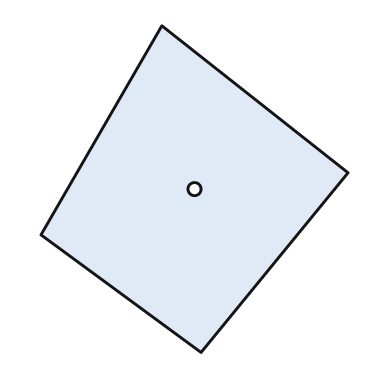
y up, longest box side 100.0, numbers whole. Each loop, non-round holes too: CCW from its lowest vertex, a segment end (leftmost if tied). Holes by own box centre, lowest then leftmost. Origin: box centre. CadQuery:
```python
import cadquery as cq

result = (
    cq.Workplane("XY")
    .moveTo(2.0, -50.0)
    .lineTo(47.0, 5.0)
    .lineTo(-10.0, 50.0)
    .lineTo(-47.0, -14.0)
    .close()
    .moveTo(0.0, 0.0)
    .circle(2.0)
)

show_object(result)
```